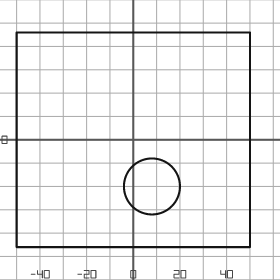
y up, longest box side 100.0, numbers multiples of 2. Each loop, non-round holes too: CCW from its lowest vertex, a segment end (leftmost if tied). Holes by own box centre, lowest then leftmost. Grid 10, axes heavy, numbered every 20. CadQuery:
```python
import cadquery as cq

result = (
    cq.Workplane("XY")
    .moveTo(-50.0, -46.0)
    .lineTo(50.0, -46.0)
    .lineTo(50.0, 46.0)
    .lineTo(-50.0, 46.0)
    .close()
    .moveTo(8.0, -20.0)
    .circle(12.0)
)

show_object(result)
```